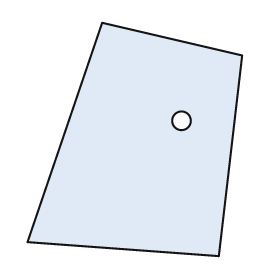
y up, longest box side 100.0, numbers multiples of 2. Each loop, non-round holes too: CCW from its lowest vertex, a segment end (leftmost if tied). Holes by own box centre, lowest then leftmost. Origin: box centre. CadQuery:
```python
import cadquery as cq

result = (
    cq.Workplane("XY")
    .moveTo(36.0, -50.0)
    .lineTo(46.0, 36.0)
    .lineTo(-14.0, 50.0)
    .lineTo(-46.0, -44.0)
    .close()
    .moveTo(20.0, 8.0)
    .circle(4.0)
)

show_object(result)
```